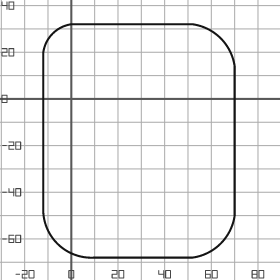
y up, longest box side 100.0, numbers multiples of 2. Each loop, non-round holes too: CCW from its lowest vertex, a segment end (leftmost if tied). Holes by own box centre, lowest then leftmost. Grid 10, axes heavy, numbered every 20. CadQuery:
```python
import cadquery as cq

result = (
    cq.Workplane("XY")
    .moveTo(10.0, -68.0)
    .lineTo(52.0, -68.0)
    .threePointArc((64.0, -62.0), (70.0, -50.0))
    .lineTo(70.0, 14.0)
    .threePointArc((64.0, 26.0), (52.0, 32.0))
    .lineTo(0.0, 32.0)
    .threePointArc((-8.0, 28.0), (-12.0, 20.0))
    .lineTo(-12.0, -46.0)
    .threePointArc((-6.0, -62.0), (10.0, -68.0))
    .close()
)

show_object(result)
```